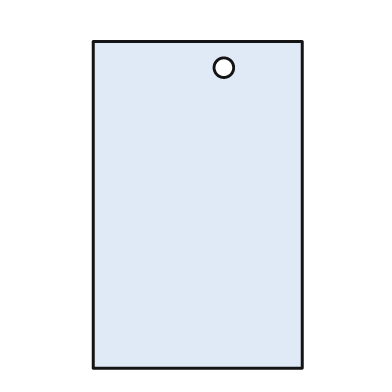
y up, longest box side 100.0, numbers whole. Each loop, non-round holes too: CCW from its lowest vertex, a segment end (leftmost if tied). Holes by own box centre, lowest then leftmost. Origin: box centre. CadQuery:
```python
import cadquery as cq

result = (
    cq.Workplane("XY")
    .moveTo(-32.0, -50.0)
    .lineTo(32.0, -50.0)
    .lineTo(32.0, 50.0)
    .lineTo(-32.0, 50.0)
    .close()
    .moveTo(8.0, 42.0)
    .circle(3.0)
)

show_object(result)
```